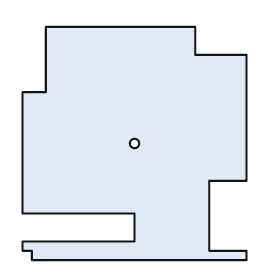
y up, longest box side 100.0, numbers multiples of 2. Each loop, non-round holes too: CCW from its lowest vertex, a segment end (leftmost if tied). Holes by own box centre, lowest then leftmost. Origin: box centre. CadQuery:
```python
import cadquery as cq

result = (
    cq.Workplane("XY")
    .moveTo(-44.0, -50.0)
    .lineTo(48.0, -50.0)
    .lineTo(48.0, -46.0)
    .lineTo(32.0, -46.0)
    .lineTo(32.0, -16.0)
    .lineTo(48.0, -16.0)
    .lineTo(48.0, 38.0)
    .lineTo(26.0, 38.0)
    .lineTo(26.0, 50.0)
    .lineTo(-38.0, 50.0)
    .lineTo(-38.0, 22.0)
    .lineTo(-48.0, 22.0)
    .lineTo(-48.0, -30.0)
    .lineTo(0.0, -30.0)
    .lineTo(0.0, -42.0)
    .lineTo(-48.0, -42.0)
    .lineTo(-48.0, -46.0)
    .lineTo(-44.0, -46.0)
    .close()
    .moveTo(0.0, 0.0)
    .circle(2.0)
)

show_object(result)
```